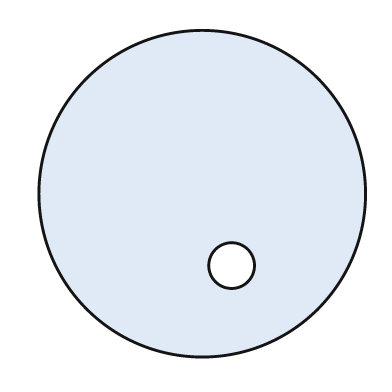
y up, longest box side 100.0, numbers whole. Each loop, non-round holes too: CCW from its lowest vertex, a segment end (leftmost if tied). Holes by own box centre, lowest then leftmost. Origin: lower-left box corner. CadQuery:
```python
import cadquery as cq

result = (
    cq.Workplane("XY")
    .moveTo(50.0, 50.0)
    .circle(50.0)
    .moveTo(59.0, 28.0)
    .circle(7.0)
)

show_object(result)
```